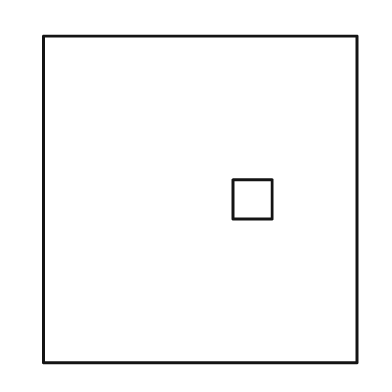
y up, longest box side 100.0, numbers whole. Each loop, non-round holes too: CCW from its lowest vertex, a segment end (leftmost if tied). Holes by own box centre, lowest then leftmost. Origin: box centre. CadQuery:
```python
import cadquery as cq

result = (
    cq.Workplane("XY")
    .moveTo(-48.0, -50.0)
    .lineTo(48.0, -50.0)
    .lineTo(48.0, 50.0)
    .lineTo(-48.0, 50.0)
    .close()
    .moveTo(10.0, -6.0)
    .lineTo(22.0, -6.0)
    .lineTo(22.0, 6.0)
    .lineTo(10.0, 6.0)
    .close()
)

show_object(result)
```